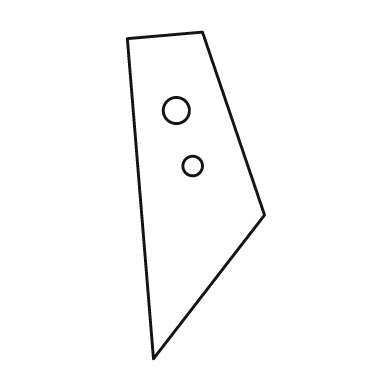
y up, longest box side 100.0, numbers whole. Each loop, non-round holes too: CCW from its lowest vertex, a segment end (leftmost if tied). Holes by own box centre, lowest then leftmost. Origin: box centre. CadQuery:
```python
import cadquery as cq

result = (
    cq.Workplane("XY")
    .moveTo(-13.0, -50.0)
    .lineTo(21.0, -6.0)
    .lineTo(2.0, 50.0)
    .lineTo(-21.0, 48.0)
    .close()
    .moveTo(-1.0, 9.0)
    .circle(3.0)
    .moveTo(-6.0, 26.0)
    .circle(4.0)
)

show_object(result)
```